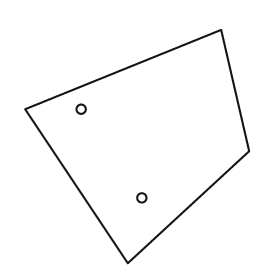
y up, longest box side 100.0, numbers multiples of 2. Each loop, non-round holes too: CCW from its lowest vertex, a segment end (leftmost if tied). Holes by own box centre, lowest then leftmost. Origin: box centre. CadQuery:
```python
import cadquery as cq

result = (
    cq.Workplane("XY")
    .moveTo(-4.0, -50.0)
    .lineTo(48.0, -2.0)
    .lineTo(36.0, 50.0)
    .lineTo(-48.0, 16.0)
    .close()
    .moveTo(2.0, -22.0)
    .circle(2.0)
    .moveTo(-24.0, 16.0)
    .circle(2.0)
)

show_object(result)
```